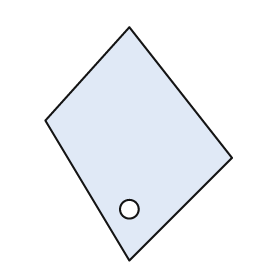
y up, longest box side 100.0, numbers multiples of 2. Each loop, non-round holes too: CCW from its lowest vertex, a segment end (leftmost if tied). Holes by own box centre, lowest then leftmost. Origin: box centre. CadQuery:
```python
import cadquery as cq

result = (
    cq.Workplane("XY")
    .moveTo(-4.0, -50.0)
    .lineTo(40.0, -6.0)
    .lineTo(-4.0, 50.0)
    .lineTo(-40.0, 10.0)
    .close()
    .moveTo(-4.0, -28.0)
    .circle(4.0)
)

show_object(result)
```